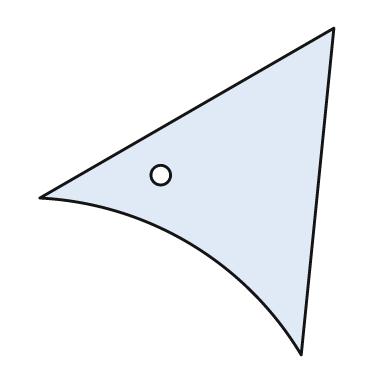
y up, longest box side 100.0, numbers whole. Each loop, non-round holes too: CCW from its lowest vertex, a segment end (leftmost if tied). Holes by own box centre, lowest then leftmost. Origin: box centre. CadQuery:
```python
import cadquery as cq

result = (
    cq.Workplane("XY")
    .moveTo(35.0, -50.0)
    .lineTo(45.0, 50.0)
    .lineTo(-45.0, -2.0)
    .threePointArc((1.0, -16.0), (35.0, -50.0))
    .close()
    .moveTo(-8.0, 5.0)
    .circle(3.0)
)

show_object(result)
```